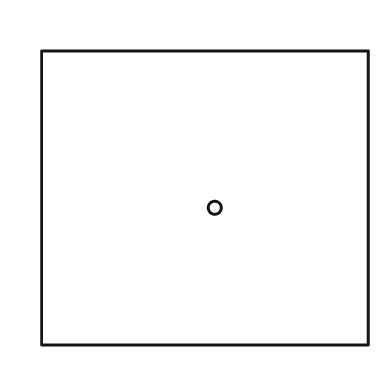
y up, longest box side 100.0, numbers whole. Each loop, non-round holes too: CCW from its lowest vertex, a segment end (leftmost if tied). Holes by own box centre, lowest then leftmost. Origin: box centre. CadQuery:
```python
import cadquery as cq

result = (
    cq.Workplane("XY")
    .moveTo(-50.0, -45.0)
    .lineTo(50.0, -45.0)
    .lineTo(50.0, 45.0)
    .lineTo(-50.0, 45.0)
    .close()
    .moveTo(3.0, -3.0)
    .circle(2.0)
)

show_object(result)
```